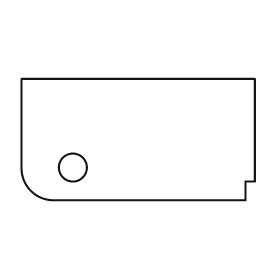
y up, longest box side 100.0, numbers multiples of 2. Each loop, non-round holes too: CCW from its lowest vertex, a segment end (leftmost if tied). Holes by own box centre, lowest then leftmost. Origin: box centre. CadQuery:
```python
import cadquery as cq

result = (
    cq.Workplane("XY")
    .moveTo(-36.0, -26.0)
    .lineTo(46.0, -26.0)
    .lineTo(46.0, -18.0)
    .lineTo(50.0, -18.0)
    .lineTo(50.0, 26.0)
    .lineTo(-50.0, 26.0)
    .lineTo(-50.0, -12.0)
    .threePointArc((-46.0, -22.0), (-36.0, -26.0))
    .close()
    .moveTo(-28.0, -12.0)
    .circle(6.0)
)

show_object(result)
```